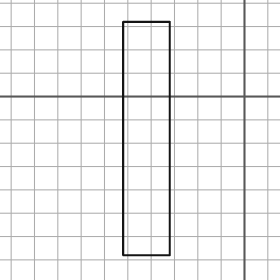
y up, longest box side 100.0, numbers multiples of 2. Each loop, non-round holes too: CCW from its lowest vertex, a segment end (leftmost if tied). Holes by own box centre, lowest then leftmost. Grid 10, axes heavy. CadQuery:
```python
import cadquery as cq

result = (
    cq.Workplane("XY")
    .moveTo(-52.0, -68.0)
    .lineTo(-32.0, -68.0)
    .lineTo(-32.0, 32.0)
    .lineTo(-52.0, 32.0)
    .close()
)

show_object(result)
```